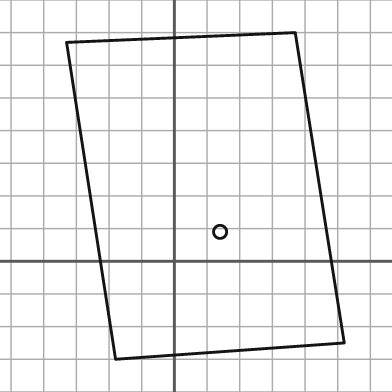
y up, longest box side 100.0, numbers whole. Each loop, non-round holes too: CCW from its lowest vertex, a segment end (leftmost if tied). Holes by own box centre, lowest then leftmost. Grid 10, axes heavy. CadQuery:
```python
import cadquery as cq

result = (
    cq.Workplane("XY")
    .moveTo(-18.0, -30.0)
    .lineTo(52.0, -25.0)
    .lineTo(37.0, 70.0)
    .lineTo(-33.0, 67.0)
    .close()
    .moveTo(14.0, 9.0)
    .circle(2.0)
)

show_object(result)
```